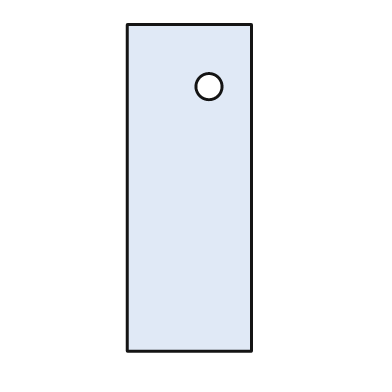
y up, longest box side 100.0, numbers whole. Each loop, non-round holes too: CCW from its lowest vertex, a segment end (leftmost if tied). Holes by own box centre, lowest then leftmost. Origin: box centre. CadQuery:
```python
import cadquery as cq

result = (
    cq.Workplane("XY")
    .moveTo(-19.0, -50.0)
    .lineTo(19.0, -50.0)
    .lineTo(19.0, 50.0)
    .lineTo(-19.0, 50.0)
    .close()
    .moveTo(6.0, 31.0)
    .circle(4.0)
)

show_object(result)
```